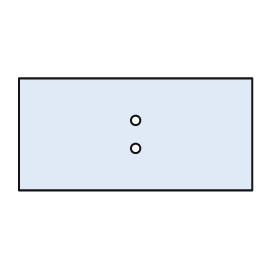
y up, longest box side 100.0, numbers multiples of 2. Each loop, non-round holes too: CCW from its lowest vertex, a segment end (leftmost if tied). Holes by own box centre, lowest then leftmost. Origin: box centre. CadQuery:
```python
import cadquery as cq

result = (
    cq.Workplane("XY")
    .moveTo(-50.0, -24.0)
    .lineTo(50.0, -24.0)
    .lineTo(50.0, 24.0)
    .lineTo(-50.0, 24.0)
    .close()
    .moveTo(0.0, -6.0)
    .circle(2.0)
    .moveTo(0.0, 6.0)
    .circle(2.0)
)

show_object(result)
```